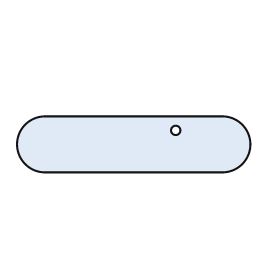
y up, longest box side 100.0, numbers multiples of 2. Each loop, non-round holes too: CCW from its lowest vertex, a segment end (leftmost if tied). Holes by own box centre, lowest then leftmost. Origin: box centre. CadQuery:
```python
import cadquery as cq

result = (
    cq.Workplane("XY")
    .moveTo(-38.0, -12.0)
    .lineTo(38.0, -12.0)
    .threePointArc((50.0, 0.0), (38.0, 12.0))
    .lineTo(-38.0, 12.0)
    .threePointArc((-50.0, 0.0), (-38.0, -12.0))
    .close()
    .moveTo(18.0, 6.0)
    .circle(2.0)
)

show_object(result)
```